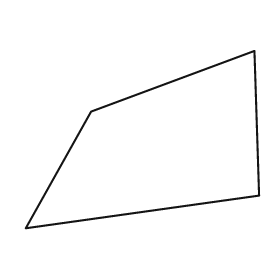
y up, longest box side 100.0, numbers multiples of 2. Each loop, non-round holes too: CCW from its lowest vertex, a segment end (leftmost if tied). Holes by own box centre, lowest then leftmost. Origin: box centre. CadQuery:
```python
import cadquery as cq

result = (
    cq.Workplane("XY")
    .moveTo(-50.0, -38.0)
    .lineTo(50.0, -24.0)
    .lineTo(48.0, 38.0)
    .lineTo(-22.0, 12.0)
    .close()
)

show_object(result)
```